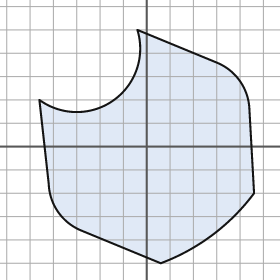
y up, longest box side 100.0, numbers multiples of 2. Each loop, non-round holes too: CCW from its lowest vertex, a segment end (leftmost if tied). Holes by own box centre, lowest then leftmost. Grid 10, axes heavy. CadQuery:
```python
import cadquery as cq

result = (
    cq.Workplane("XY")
    .moveTo(6.0, -50.0)
    .threePointArc((28.0, -38.0), (46.0, -20.0))
    .lineTo(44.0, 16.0)
    .threePointArc((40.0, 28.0), (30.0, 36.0))
    .lineTo(-4.0, 50.0)
    .threePointArc((-14.0, 20.0), (-46.0, 20.0))
    .lineTo(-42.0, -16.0)
    .threePointArc((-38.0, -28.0), (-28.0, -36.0))
    .close()
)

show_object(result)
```